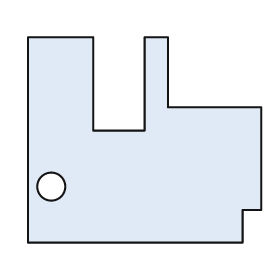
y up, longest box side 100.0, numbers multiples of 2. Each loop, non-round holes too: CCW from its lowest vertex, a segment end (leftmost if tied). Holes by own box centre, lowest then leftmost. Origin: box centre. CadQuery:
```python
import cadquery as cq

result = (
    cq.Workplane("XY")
    .moveTo(-50.0, -44.0)
    .lineTo(42.0, -44.0)
    .lineTo(42.0, -30.0)
    .lineTo(50.0, -30.0)
    .lineTo(50.0, 14.0)
    .lineTo(10.0, 14.0)
    .lineTo(10.0, 44.0)
    .lineTo(0.0, 44.0)
    .lineTo(0.0, 4.0)
    .lineTo(-22.0, 4.0)
    .lineTo(-22.0, 44.0)
    .lineTo(-50.0, 44.0)
    .close()
    .moveTo(-40.0, -20.0)
    .circle(6.0)
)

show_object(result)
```